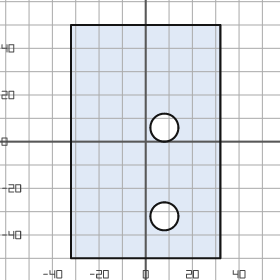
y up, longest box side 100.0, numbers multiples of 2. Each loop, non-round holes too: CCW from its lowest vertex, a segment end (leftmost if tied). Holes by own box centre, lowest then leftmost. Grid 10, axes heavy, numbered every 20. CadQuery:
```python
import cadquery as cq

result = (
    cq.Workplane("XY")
    .moveTo(-32.0, -50.0)
    .lineTo(32.0, -50.0)
    .lineTo(32.0, 50.0)
    .lineTo(-32.0, 50.0)
    .close()
    .moveTo(8.0, -32.0)
    .circle(6.0)
    .moveTo(8.0, 6.0)
    .circle(6.0)
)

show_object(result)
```